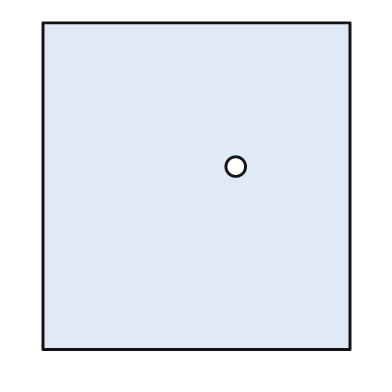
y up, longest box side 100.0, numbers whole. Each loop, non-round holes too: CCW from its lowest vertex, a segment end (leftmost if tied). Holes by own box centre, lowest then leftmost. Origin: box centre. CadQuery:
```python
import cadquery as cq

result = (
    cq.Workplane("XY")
    .moveTo(-47.0, -50.0)
    .lineTo(47.0, -50.0)
    .lineTo(47.0, 50.0)
    .lineTo(-47.0, 50.0)
    .close()
    .moveTo(12.0, 6.0)
    .circle(3.0)
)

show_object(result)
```